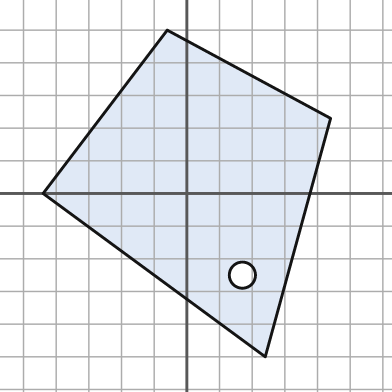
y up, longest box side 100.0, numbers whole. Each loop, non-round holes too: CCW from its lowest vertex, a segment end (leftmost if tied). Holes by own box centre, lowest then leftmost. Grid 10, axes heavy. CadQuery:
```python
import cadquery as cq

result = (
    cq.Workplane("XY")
    .moveTo(24.0, -50.0)
    .lineTo(44.0, 23.0)
    .lineTo(-6.0, 50.0)
    .lineTo(-44.0, 0.0)
    .close()
    .moveTo(17.0, -25.0)
    .circle(4.0)
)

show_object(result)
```